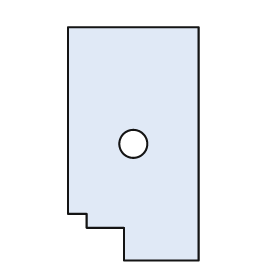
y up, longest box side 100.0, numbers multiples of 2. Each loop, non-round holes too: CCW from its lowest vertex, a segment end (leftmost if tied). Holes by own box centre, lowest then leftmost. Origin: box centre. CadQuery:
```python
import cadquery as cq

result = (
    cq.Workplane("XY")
    .moveTo(-4.0, -50.0)
    .lineTo(28.0, -50.0)
    .lineTo(28.0, 50.0)
    .lineTo(-28.0, 50.0)
    .lineTo(-28.0, -30.0)
    .lineTo(-20.0, -30.0)
    .lineTo(-20.0, -36.0)
    .lineTo(-4.0, -36.0)
    .close()
    .moveTo(0.0, 0.0)
    .circle(6.0)
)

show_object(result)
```